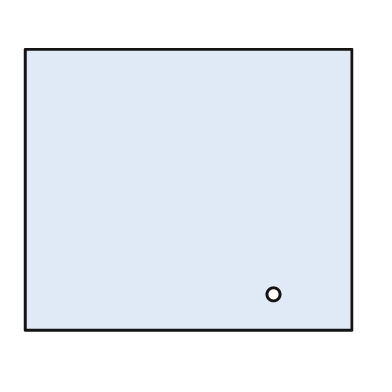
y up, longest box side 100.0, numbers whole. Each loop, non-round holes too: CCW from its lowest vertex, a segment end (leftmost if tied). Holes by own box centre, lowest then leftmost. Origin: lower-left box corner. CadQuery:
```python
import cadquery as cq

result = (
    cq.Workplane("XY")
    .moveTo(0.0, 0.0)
    .lineTo(100.0, 0.0)
    .lineTo(100.0, 86.0)
    .lineTo(0.0, 86.0)
    .close()
    .moveTo(76.0, 11.0)
    .circle(2.0)
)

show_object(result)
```